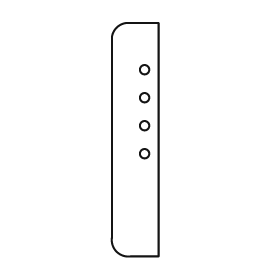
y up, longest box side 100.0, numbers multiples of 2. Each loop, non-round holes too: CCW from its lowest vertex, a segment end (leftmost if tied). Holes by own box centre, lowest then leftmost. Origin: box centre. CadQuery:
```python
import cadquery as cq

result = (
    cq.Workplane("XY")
    .moveTo(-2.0, -50.0)
    .lineTo(10.0, -50.0)
    .lineTo(10.0, 50.0)
    .lineTo(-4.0, 50.0)
    .threePointArc((-8.0, 48.0), (-10.0, 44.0))
    .lineTo(-10.0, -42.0)
    .threePointArc((-8.0, -48.0), (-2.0, -50.0))
    .close()
    .moveTo(4.0, -6.0)
    .circle(2.0)
    .moveTo(4.0, 6.0)
    .circle(2.0)
    .moveTo(4.0, 18.0)
    .circle(2.0)
    .moveTo(4.0, 30.0)
    .circle(2.0)
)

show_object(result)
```